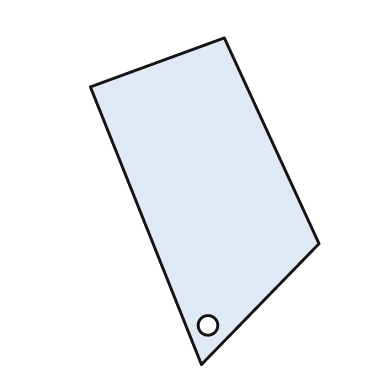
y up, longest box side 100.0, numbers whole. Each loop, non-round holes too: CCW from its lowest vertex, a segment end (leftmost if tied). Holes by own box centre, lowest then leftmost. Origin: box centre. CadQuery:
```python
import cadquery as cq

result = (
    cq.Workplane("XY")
    .moveTo(-1.0, -50.0)
    .lineTo(35.0, -13.0)
    .lineTo(6.0, 50.0)
    .lineTo(-35.0, 35.0)
    .close()
    .moveTo(1.0, -38.0)
    .circle(3.0)
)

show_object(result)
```